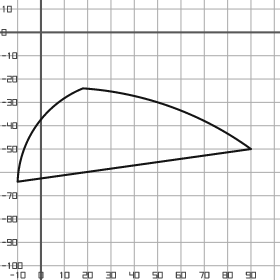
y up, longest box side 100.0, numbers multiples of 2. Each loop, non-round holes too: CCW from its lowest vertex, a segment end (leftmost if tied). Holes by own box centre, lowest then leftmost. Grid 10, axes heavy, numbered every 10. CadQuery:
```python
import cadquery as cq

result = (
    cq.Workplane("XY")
    .moveTo(-10.0, -64.0)
    .lineTo(90.0, -50.0)
    .threePointArc((56.0, -32.0), (18.0, -24.0))
    .threePointArc((-2.0, -40.0), (-10.0, -64.0))
    .close()
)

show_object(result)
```